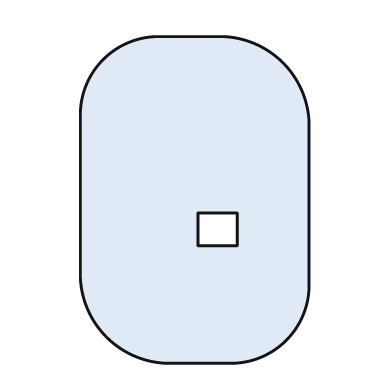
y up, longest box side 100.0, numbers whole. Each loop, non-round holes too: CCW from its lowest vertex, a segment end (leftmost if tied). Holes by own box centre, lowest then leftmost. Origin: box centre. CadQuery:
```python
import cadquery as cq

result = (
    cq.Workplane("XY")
    .moveTo(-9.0, -50.0)
    .lineTo(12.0, -50.0)
    .threePointArc((28.0, -43.0), (35.0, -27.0))
    .lineTo(35.0, 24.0)
    .threePointArc((27.0, 42.0), (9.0, 50.0))
    .lineTo(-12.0, 50.0)
    .threePointArc((-28.0, 43.0), (-35.0, 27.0))
    .lineTo(-35.0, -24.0)
    .threePointArc((-27.0, -42.0), (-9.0, -50.0))
    .close()
    .moveTo(1.0, -14.0)
    .lineTo(13.0, -14.0)
    .lineTo(13.0, -4.0)
    .lineTo(1.0, -4.0)
    .close()
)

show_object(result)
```